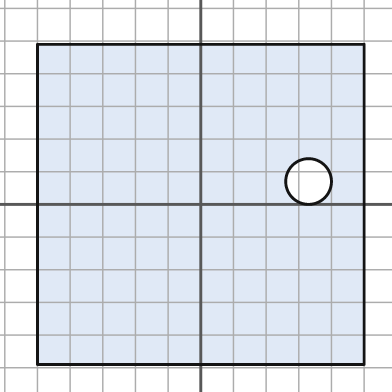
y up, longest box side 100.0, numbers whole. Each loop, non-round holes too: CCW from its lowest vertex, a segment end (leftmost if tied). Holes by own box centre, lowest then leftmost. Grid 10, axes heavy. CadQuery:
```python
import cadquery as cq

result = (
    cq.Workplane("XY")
    .moveTo(-50.0, -49.0)
    .lineTo(50.0, -49.0)
    .lineTo(50.0, 49.0)
    .lineTo(-50.0, 49.0)
    .close()
    .moveTo(33.0, 7.0)
    .circle(7.0)
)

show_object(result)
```